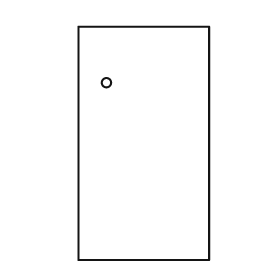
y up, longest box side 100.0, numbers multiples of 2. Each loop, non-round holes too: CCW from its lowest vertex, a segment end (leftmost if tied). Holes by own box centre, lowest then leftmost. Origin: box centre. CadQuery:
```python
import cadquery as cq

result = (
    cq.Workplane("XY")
    .moveTo(-28.0, -50.0)
    .lineTo(28.0, -50.0)
    .lineTo(28.0, 50.0)
    .lineTo(-28.0, 50.0)
    .close()
    .moveTo(-16.0, 26.0)
    .circle(2.0)
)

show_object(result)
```